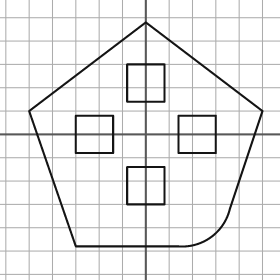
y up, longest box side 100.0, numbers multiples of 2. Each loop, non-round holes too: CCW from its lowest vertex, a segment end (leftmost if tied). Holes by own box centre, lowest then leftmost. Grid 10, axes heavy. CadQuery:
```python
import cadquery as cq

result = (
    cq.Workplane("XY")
    .moveTo(-30.0, -48.0)
    .lineTo(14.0, -48.0)
    .threePointArc((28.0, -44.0), (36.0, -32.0))
    .lineTo(50.0, 10.0)
    .lineTo(0.0, 48.0)
    .lineTo(-50.0, 10.0)
    .close()
    .moveTo(-8.0, -30.0)
    .lineTo(8.0, -30.0)
    .lineTo(8.0, -14.0)
    .lineTo(-8.0, -14.0)
    .close()
    .moveTo(-30.0, -8.0)
    .lineTo(-14.0, -8.0)
    .lineTo(-14.0, 8.0)
    .lineTo(-30.0, 8.0)
    .close()
    .moveTo(14.0, -8.0)
    .lineTo(30.0, -8.0)
    .lineTo(30.0, 8.0)
    .lineTo(14.0, 8.0)
    .close()
    .moveTo(-8.0, 14.0)
    .lineTo(8.0, 14.0)
    .lineTo(8.0, 30.0)
    .lineTo(-8.0, 30.0)
    .close()
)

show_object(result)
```